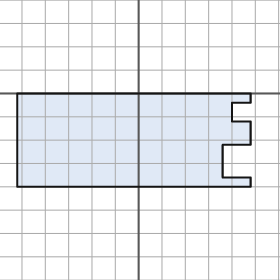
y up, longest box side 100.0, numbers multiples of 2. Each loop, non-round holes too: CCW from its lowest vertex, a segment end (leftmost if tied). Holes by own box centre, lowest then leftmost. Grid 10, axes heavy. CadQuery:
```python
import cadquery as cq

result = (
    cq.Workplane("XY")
    .moveTo(-52.0, -40.0)
    .lineTo(48.0, -40.0)
    .lineTo(48.0, -36.0)
    .lineTo(36.0, -36.0)
    .lineTo(36.0, -22.0)
    .lineTo(48.0, -22.0)
    .lineTo(48.0, -12.0)
    .lineTo(40.0, -12.0)
    .lineTo(40.0, -4.0)
    .lineTo(48.0, -4.0)
    .lineTo(48.0, 0.0)
    .lineTo(-52.0, 0.0)
    .close()
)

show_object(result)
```